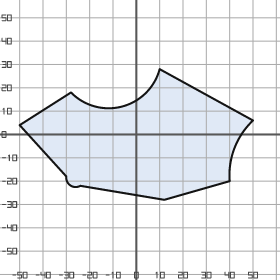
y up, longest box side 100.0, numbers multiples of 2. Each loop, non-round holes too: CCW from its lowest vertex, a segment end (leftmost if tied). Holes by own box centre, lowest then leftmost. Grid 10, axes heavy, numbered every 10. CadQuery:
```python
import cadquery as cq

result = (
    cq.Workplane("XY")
    .moveTo(12.0, -28.0)
    .lineTo(40.0, -20.0)
    .threePointArc((42.0, -6.0), (50.0, 6.0))
    .lineTo(10.0, 28.0)
    .threePointArc((-6.0, 12.0), (-28.0, 18.0))
    .lineTo(-50.0, 4.0)
    .lineTo(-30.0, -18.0)
    .threePointArc((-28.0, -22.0), (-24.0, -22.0))
    .close()
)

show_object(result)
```